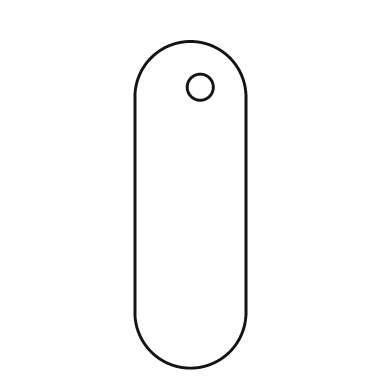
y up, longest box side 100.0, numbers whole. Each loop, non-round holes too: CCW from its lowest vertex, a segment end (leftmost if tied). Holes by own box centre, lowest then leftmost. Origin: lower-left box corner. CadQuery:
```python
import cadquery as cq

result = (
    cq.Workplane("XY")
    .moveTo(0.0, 17.0)
    .threePointArc((17.0, 0.0), (34.0, 17.0))
    .lineTo(34.0, 83.0)
    .threePointArc((17.0, 100.0), (0.0, 83.0))
    .close()
    .moveTo(20.0, 86.0)
    .circle(4.0)
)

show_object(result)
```